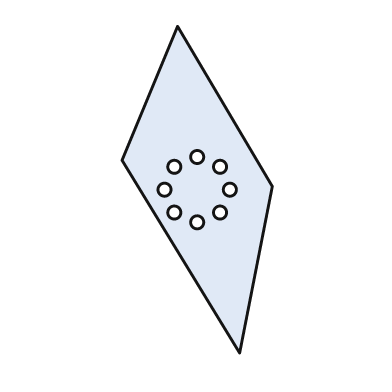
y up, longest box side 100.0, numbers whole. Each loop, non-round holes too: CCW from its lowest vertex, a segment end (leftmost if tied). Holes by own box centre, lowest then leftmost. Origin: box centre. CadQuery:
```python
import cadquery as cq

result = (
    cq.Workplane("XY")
    .moveTo(13.0, -50.0)
    .lineTo(23.0, 1.0)
    .lineTo(-6.0, 50.0)
    .lineTo(-23.0, 9.0)
    .close()
    .moveTo(0.0, -10.0)
    .circle(2.0)
    .moveTo(-7.0, -7.0)
    .circle(2.0)
    .moveTo(7.0, -7.0)
    .circle(2.0)
    .moveTo(-10.0, 0.0)
    .circle(2.0)
    .moveTo(10.0, 0.0)
    .circle(2.0)
    .moveTo(-7.0, 7.0)
    .circle(2.0)
    .moveTo(7.0, 7.0)
    .circle(2.0)
    .moveTo(0.0, 10.0)
    .circle(2.0)
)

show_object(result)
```